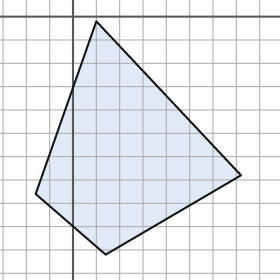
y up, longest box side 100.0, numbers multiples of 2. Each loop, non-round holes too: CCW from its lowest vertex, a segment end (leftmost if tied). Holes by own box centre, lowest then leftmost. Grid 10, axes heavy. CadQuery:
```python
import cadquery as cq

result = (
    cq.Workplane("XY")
    .moveTo(14.0, -102.0)
    .lineTo(72.0, -68.0)
    .lineTo(10.0, -2.0)
    .lineTo(-16.0, -76.0)
    .close()
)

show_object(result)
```